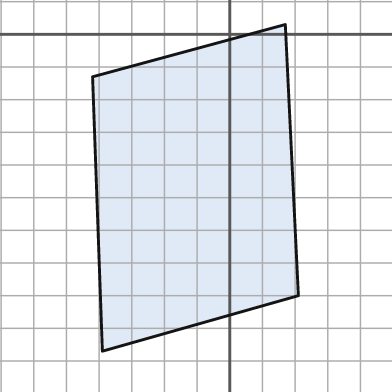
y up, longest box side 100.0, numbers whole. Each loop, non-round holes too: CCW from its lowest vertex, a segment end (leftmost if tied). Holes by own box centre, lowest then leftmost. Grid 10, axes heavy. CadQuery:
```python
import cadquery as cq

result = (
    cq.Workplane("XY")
    .moveTo(-39.0, -97.0)
    .lineTo(21.0, -80.0)
    .lineTo(17.0, 3.0)
    .lineTo(-42.0, -13.0)
    .close()
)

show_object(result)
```